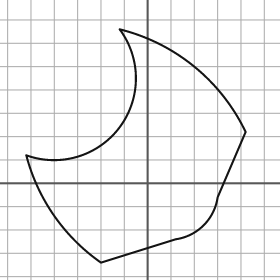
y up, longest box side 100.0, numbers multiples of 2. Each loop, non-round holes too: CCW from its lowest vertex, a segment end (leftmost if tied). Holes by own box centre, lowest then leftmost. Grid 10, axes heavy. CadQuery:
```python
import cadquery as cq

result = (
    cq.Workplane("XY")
    .moveTo(-20.0, -34.0)
    .lineTo(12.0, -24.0)
    .threePointArc((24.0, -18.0), (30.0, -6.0))
    .lineTo(42.0, 22.0)
    .threePointArc((20.0, 50.0), (-12.0, 66.0))
    .threePointArc((-12.0, 24.0), (-52.0, 12.0))
    .threePointArc((-40.0, -14.0), (-20.0, -34.0))
    .close()
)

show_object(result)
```